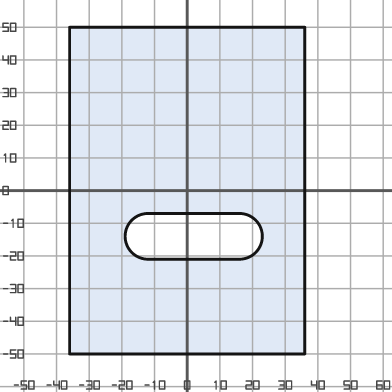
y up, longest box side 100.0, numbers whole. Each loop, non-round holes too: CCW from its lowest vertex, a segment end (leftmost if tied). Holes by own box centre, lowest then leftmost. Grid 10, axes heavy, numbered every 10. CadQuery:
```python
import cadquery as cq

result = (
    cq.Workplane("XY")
    .moveTo(-36.0, -50.0)
    .lineTo(36.0, -50.0)
    .lineTo(36.0, 50.0)
    .lineTo(-36.0, 50.0)
    .close()
    .moveTo(-12.0, -21.0)
    .lineTo(16.0, -21.0)
    .threePointArc((23.0, -14.0), (16.0, -7.0))
    .lineTo(-12.0, -7.0)
    .threePointArc((-19.0, -14.0), (-12.0, -21.0))
    .close()
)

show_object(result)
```